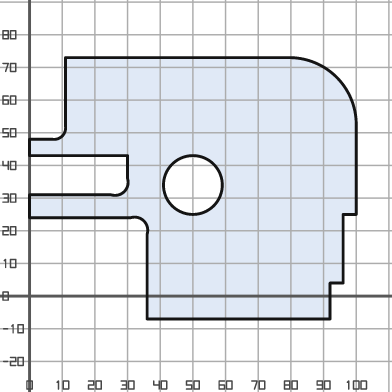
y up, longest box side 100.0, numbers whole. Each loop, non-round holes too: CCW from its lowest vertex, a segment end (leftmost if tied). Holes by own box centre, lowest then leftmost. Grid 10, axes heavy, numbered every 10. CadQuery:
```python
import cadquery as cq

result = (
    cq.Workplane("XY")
    .moveTo(36.0, -7.0)
    .lineTo(92.0, -7.0)
    .lineTo(92.0, 4.0)
    .lineTo(96.0, 4.0)
    .lineTo(96.0, 25.0)
    .lineTo(100.0, 25.0)
    .lineTo(100.0, 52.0)
    .threePointArc((94.0, 67.0), (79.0, 73.0))
    .lineTo(11.0, 73.0)
    .lineTo(11.0, 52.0)
    .threePointArc((10.0, 49.0), (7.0, 48.0))
    .lineTo(0.0, 48.0)
    .lineTo(0.0, 43.0)
    .lineTo(30.0, 43.0)
    .lineTo(30.0, 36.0)
    .threePointArc((29.0, 32.0), (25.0, 31.0))
    .lineTo(0.0, 31.0)
    .lineTo(0.0, 24.0)
    .lineTo(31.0, 24.0)
    .threePointArc((35.0, 23.0), (36.0, 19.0))
    .close()
    .moveTo(50.0, 34.0)
    .circle(9.0)
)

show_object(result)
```